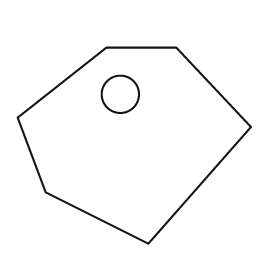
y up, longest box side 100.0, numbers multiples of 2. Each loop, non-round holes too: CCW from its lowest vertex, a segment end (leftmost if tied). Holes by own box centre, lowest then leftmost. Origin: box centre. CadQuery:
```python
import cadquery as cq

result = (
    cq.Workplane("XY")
    .moveTo(6.0, -42.0)
    .lineTo(50.0, 8.0)
    .lineTo(18.0, 42.0)
    .lineTo(-12.0, 42.0)
    .lineTo(-50.0, 12.0)
    .lineTo(-38.0, -20.0)
    .close()
    .moveTo(-6.0, 22.0)
    .circle(8.0)
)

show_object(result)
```